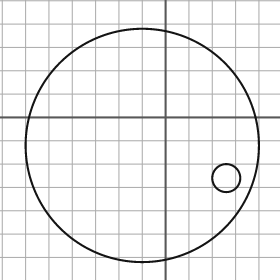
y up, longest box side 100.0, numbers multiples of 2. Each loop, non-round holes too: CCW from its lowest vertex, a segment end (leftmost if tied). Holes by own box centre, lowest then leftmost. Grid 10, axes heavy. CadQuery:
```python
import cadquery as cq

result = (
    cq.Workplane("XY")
    .moveTo(-10.0, -12.0)
    .circle(50.0)
    .moveTo(26.0, -26.0)
    .circle(6.0)
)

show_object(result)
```